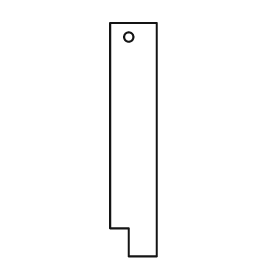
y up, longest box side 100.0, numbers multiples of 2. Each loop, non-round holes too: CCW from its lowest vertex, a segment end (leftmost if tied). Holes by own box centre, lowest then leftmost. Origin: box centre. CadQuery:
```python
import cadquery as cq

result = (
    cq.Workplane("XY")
    .moveTo(-2.0, -50.0)
    .lineTo(10.0, -50.0)
    .lineTo(10.0, 50.0)
    .lineTo(-10.0, 50.0)
    .lineTo(-10.0, -38.0)
    .lineTo(-2.0, -38.0)
    .close()
    .moveTo(-2.0, 44.0)
    .circle(2.0)
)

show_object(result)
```